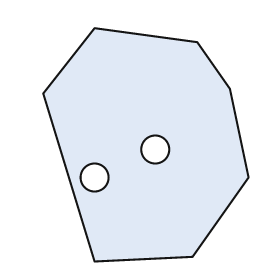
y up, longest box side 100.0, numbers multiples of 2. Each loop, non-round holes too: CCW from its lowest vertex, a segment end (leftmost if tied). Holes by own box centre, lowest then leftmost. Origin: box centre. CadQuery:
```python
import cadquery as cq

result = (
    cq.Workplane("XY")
    .moveTo(-22.0, -50.0)
    .lineTo(20.0, -48.0)
    .lineTo(44.0, -14.0)
    .lineTo(36.0, 24.0)
    .lineTo(22.0, 44.0)
    .lineTo(-22.0, 50.0)
    .lineTo(-44.0, 22.0)
    .close()
    .moveTo(-22.0, -14.0)
    .circle(6.0)
    .moveTo(4.0, -2.0)
    .circle(6.0)
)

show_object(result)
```